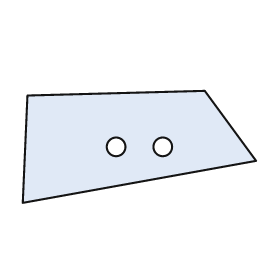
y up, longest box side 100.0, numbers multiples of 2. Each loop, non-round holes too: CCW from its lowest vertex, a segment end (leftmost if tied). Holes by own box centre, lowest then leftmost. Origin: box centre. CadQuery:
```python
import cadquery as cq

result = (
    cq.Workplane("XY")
    .moveTo(-50.0, -24.0)
    .lineTo(50.0, -6.0)
    .lineTo(28.0, 24.0)
    .lineTo(-48.0, 22.0)
    .close()
    .moveTo(-10.0, 0.0)
    .circle(4.0)
    .moveTo(10.0, 0.0)
    .circle(4.0)
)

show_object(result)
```